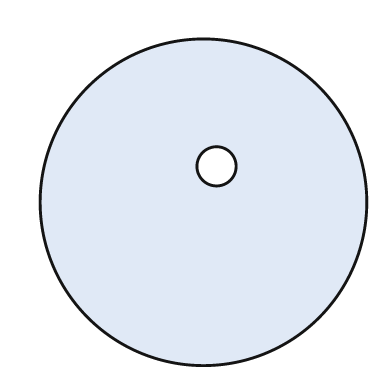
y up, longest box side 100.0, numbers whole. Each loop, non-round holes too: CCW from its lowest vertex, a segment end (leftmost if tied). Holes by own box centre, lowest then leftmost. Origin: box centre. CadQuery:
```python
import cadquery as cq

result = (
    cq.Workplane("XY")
    .moveTo(0.0, 0.0)
    .circle(50.0)
    .moveTo(4.0, 11.0)
    .circle(6.0)
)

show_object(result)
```